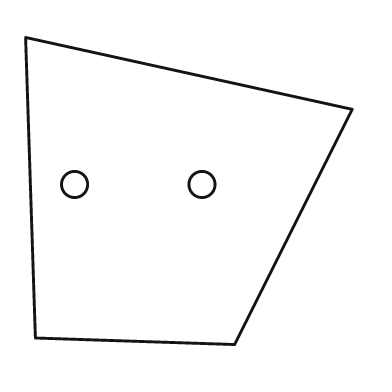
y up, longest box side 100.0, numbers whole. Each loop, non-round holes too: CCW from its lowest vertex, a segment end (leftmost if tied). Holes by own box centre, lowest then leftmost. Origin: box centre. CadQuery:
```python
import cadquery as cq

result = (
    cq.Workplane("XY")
    .moveTo(14.0, -47.0)
    .lineTo(50.0, 25.0)
    .lineTo(-50.0, 47.0)
    .lineTo(-47.0, -45.0)
    .close()
    .moveTo(-35.0, 2.0)
    .circle(4.0)
    .moveTo(4.0, 2.0)
    .circle(4.0)
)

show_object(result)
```